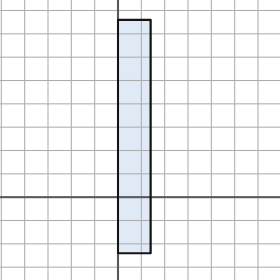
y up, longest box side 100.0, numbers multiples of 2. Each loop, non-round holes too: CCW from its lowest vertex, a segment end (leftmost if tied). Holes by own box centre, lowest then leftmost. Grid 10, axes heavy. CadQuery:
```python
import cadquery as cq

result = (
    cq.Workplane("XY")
    .moveTo(0.0, -24.0)
    .lineTo(14.0, -24.0)
    .lineTo(14.0, 76.0)
    .lineTo(0.0, 76.0)
    .close()
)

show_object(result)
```